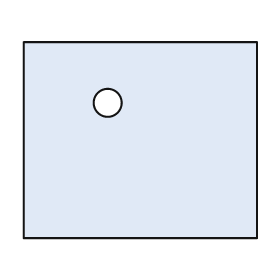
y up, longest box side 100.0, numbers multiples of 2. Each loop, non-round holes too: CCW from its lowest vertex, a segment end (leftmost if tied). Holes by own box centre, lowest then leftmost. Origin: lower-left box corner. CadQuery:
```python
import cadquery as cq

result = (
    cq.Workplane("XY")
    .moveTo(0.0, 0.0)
    .lineTo(100.0, 0.0)
    .lineTo(100.0, 84.0)
    .lineTo(0.0, 84.0)
    .close()
    .moveTo(36.0, 58.0)
    .circle(6.0)
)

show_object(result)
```